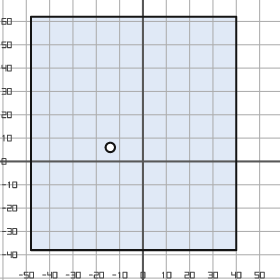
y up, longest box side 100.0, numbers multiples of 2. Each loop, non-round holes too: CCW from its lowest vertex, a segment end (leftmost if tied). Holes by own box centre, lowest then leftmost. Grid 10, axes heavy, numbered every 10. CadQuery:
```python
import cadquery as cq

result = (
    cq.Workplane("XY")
    .moveTo(-48.0, -38.0)
    .lineTo(40.0, -38.0)
    .lineTo(40.0, 62.0)
    .lineTo(-48.0, 62.0)
    .close()
    .moveTo(-14.0, 6.0)
    .circle(2.0)
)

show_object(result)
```